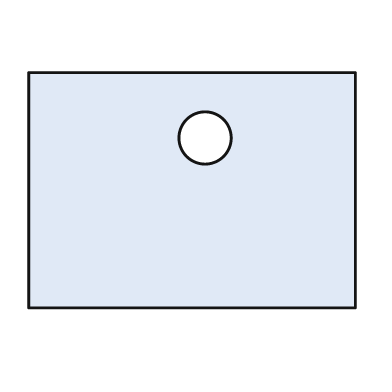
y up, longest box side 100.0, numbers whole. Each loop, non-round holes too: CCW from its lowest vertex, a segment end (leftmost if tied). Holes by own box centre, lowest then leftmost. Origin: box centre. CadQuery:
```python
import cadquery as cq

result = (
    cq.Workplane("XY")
    .moveTo(-50.0, -36.0)
    .lineTo(50.0, -36.0)
    .lineTo(50.0, 36.0)
    .lineTo(-50.0, 36.0)
    .close()
    .moveTo(4.0, 16.0)
    .circle(8.0)
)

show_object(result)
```